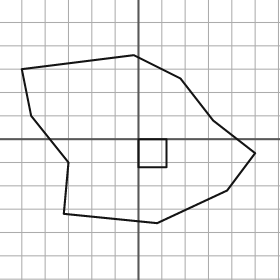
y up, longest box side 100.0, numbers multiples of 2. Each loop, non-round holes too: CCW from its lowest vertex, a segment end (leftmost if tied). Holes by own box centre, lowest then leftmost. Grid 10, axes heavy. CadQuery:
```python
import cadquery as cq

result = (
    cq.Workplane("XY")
    .moveTo(8.0, -36.0)
    .lineTo(38.0, -22.0)
    .lineTo(50.0, -6.0)
    .lineTo(32.0, 8.0)
    .lineTo(18.0, 26.0)
    .lineTo(-2.0, 36.0)
    .lineTo(-50.0, 30.0)
    .lineTo(-46.0, 10.0)
    .lineTo(-30.0, -10.0)
    .lineTo(-32.0, -32.0)
    .close()
    .moveTo(0.0, -12.0)
    .lineTo(12.0, -12.0)
    .lineTo(12.0, 0.0)
    .lineTo(0.0, 0.0)
    .close()
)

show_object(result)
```